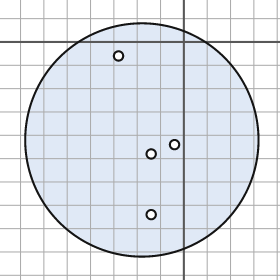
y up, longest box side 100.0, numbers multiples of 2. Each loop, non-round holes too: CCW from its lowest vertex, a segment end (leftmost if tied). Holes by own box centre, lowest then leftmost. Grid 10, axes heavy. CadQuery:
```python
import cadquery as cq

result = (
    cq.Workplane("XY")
    .moveTo(-18.0, -42.0)
    .circle(50.0)
    .moveTo(-14.0, -74.0)
    .circle(2.0)
    .moveTo(-14.0, -48.0)
    .circle(2.0)
    .moveTo(-4.0, -44.0)
    .circle(2.0)
    .moveTo(-28.0, -6.0)
    .circle(2.0)
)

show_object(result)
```